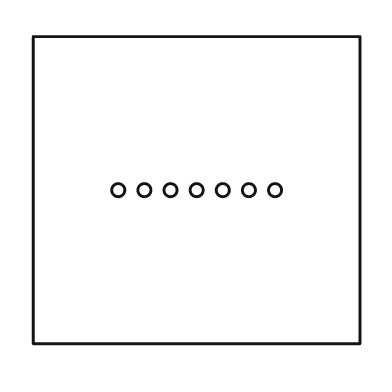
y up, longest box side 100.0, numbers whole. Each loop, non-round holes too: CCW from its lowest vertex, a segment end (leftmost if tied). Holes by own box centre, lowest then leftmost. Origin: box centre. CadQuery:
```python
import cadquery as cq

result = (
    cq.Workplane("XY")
    .moveTo(-50.0, -47.0)
    .lineTo(50.0, -47.0)
    .lineTo(50.0, 47.0)
    .lineTo(-50.0, 47.0)
    .close()
    .moveTo(-24.0, 0.0)
    .circle(2.0)
    .moveTo(-16.0, 0.0)
    .circle(2.0)
    .moveTo(-8.0, 0.0)
    .circle(2.0)
    .moveTo(0.0, 0.0)
    .circle(2.0)
    .moveTo(8.0, 0.0)
    .circle(2.0)
    .moveTo(16.0, 0.0)
    .circle(2.0)
    .moveTo(24.0, 0.0)
    .circle(2.0)
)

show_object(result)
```